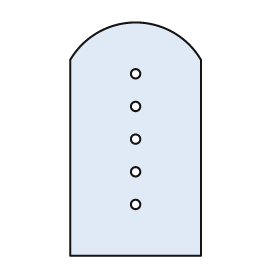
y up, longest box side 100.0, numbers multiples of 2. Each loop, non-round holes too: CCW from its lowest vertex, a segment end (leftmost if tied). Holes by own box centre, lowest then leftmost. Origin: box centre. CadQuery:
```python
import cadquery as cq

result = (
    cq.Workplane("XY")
    .moveTo(-28.0, -50.0)
    .lineTo(28.0, -50.0)
    .lineTo(28.0, 34.0)
    .threePointArc((0.0, 50.0), (-28.0, 34.0))
    .close()
    .moveTo(0.0, -28.0)
    .circle(2.0)
    .moveTo(0.0, -14.0)
    .circle(2.0)
    .moveTo(0.0, 0.0)
    .circle(2.0)
    .moveTo(0.0, 14.0)
    .circle(2.0)
    .moveTo(0.0, 28.0)
    .circle(2.0)
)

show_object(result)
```